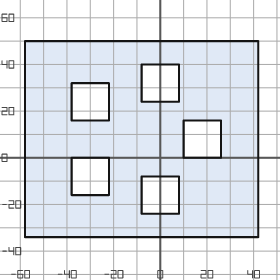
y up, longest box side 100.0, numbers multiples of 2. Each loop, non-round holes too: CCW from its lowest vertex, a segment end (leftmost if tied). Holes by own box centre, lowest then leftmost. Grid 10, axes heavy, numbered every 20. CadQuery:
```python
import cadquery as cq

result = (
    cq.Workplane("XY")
    .moveTo(-58.0, -34.0)
    .lineTo(42.0, -34.0)
    .lineTo(42.0, 50.0)
    .lineTo(-58.0, 50.0)
    .close()
    .moveTo(-8.0, -24.0)
    .lineTo(8.0, -24.0)
    .lineTo(8.0, -8.0)
    .lineTo(-8.0, -8.0)
    .close()
    .moveTo(-38.0, -16.0)
    .lineTo(-22.0, -16.0)
    .lineTo(-22.0, 0.0)
    .lineTo(-38.0, 0.0)
    .close()
    .moveTo(10.0, 0.0)
    .lineTo(26.0, 0.0)
    .lineTo(26.0, 16.0)
    .lineTo(10.0, 16.0)
    .close()
    .moveTo(-38.0, 16.0)
    .lineTo(-22.0, 16.0)
    .lineTo(-22.0, 32.0)
    .lineTo(-38.0, 32.0)
    .close()
    .moveTo(-8.0, 24.0)
    .lineTo(8.0, 24.0)
    .lineTo(8.0, 40.0)
    .lineTo(-8.0, 40.0)
    .close()
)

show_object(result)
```